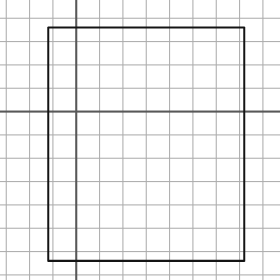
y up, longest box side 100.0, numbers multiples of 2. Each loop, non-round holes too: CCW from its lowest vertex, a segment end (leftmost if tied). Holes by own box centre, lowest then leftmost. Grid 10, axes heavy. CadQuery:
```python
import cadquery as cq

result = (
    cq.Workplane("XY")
    .moveTo(-12.0, -64.0)
    .lineTo(72.0, -64.0)
    .lineTo(72.0, 36.0)
    .lineTo(-12.0, 36.0)
    .close()
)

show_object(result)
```